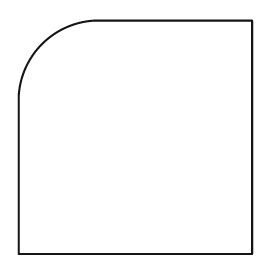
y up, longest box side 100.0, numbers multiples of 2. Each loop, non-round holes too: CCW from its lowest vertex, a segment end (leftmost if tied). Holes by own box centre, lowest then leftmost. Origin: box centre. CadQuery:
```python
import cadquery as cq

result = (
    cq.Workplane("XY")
    .moveTo(-50.0, -50.0)
    .lineTo(50.0, -50.0)
    .lineTo(50.0, 50.0)
    .lineTo(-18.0, 50.0)
    .threePointArc((-40.0, 40.0), (-50.0, 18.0))
    .close()
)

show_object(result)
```